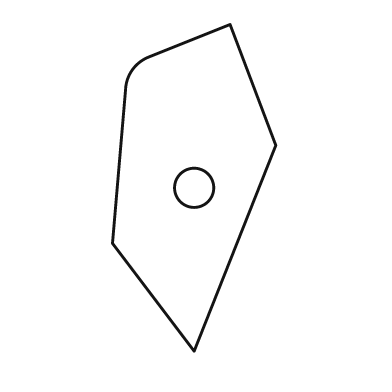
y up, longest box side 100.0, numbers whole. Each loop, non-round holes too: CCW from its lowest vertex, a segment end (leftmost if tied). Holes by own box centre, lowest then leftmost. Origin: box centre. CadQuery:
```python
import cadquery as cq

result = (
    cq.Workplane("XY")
    .moveTo(0.0, -50.0)
    .lineTo(25.0, 13.0)
    .lineTo(11.0, 50.0)
    .lineTo(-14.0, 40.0)
    .threePointArc((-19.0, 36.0), (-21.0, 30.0))
    .lineTo(-25.0, -17.0)
    .close()
    .moveTo(0.0, 0.0)
    .circle(6.0)
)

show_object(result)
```